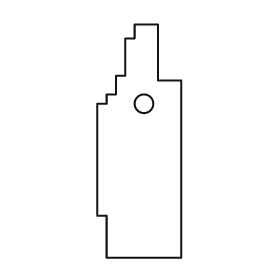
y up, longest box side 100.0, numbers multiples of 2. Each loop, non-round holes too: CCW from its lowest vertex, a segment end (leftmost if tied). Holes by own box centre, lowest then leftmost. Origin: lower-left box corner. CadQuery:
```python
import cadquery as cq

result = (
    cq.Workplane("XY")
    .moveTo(4.0, 0.0)
    .lineTo(36.0, 0.0)
    .lineTo(36.0, 76.0)
    .lineTo(26.0, 76.0)
    .lineTo(26.0, 100.0)
    .lineTo(16.0, 100.0)
    .lineTo(16.0, 94.0)
    .lineTo(12.0, 94.0)
    .lineTo(12.0, 78.0)
    .lineTo(8.0, 78.0)
    .lineTo(8.0, 70.0)
    .lineTo(4.0, 70.0)
    .lineTo(4.0, 66.0)
    .lineTo(0.0, 66.0)
    .lineTo(0.0, 18.0)
    .lineTo(4.0, 18.0)
    .close()
    .moveTo(20.0, 66.0)
    .circle(4.0)
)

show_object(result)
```